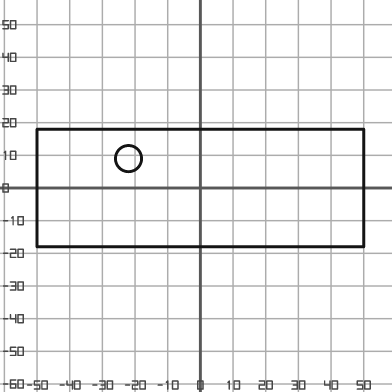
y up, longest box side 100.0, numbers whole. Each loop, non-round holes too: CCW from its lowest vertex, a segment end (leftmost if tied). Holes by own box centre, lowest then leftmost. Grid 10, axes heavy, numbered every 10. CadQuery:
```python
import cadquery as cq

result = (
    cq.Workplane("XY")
    .moveTo(-50.0, -18.0)
    .lineTo(50.0, -18.0)
    .lineTo(50.0, 18.0)
    .lineTo(-50.0, 18.0)
    .close()
    .moveTo(-22.0, 9.0)
    .circle(4.0)
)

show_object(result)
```